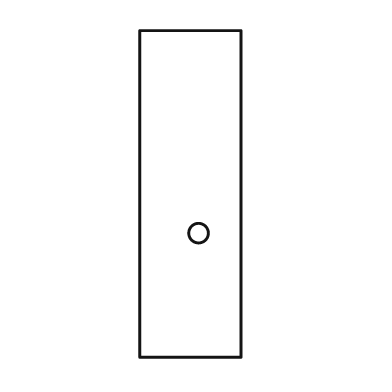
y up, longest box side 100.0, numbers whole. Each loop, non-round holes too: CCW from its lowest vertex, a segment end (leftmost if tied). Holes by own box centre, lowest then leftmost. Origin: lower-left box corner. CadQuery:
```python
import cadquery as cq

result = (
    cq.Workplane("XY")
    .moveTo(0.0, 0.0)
    .lineTo(31.0, 0.0)
    .lineTo(31.0, 100.0)
    .lineTo(0.0, 100.0)
    .close()
    .moveTo(18.0, 38.0)
    .circle(3.0)
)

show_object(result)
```